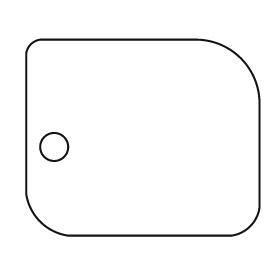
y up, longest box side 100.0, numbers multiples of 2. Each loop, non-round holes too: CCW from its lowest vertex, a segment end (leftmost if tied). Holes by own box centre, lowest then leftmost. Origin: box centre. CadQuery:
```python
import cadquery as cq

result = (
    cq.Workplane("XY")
    .moveTo(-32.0, -42.0)
    .lineTo(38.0, -42.0)
    .threePointArc((46.0, -38.0), (50.0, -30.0))
    .lineTo(50.0, 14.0)
    .threePointArc((42.0, 34.0), (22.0, 42.0))
    .lineTo(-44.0, 42.0)
    .threePointArc((-48.0, 40.0), (-50.0, 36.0))
    .lineTo(-50.0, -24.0)
    .threePointArc((-44.0, -36.0), (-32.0, -42.0))
    .close()
    .moveTo(-38.0, -4.0)
    .circle(6.0)
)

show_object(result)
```